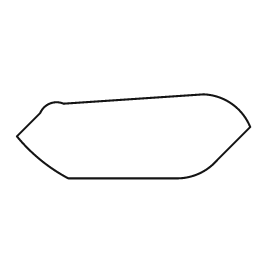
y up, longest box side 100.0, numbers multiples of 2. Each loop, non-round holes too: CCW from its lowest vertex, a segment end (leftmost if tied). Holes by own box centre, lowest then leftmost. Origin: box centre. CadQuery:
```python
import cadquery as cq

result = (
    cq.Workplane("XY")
    .moveTo(-28.0, -18.0)
    .lineTo(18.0, -18.0)
    .threePointArc((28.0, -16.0), (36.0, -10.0))
    .lineTo(50.0, 4.0)
    .threePointArc((42.0, 14.0), (30.0, 18.0))
    .lineTo(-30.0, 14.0)
    .threePointArc((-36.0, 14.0), (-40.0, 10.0))
    .lineTo(-50.0, 0.0)
    .threePointArc((-40.0, -10.0), (-28.0, -18.0))
    .close()
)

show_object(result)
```